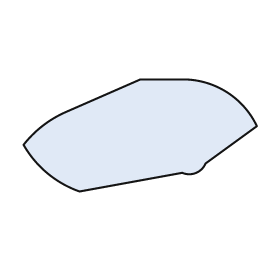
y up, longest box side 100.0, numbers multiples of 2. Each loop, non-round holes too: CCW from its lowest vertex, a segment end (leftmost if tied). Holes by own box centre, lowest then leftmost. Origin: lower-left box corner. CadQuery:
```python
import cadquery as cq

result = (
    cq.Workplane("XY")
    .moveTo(24.0, 0.0)
    .lineTo(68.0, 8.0)
    .threePointArc((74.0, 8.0), (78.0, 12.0))
    .lineTo(100.0, 28.0)
    .threePointArc((88.0, 42.0), (70.0, 48.0))
    .lineTo(50.0, 48.0)
    .lineTo(18.0, 34.0)
    .threePointArc((8.0, 28.0), (0.0, 20.0))
    .threePointArc((10.0, 8.0), (24.0, 0.0))
    .close()
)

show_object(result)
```